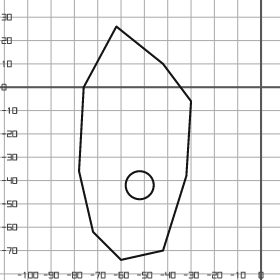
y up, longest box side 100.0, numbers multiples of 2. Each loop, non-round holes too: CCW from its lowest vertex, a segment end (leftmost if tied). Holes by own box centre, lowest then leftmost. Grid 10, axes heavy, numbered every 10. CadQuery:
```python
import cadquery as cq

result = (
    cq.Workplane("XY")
    .moveTo(-60.0, -74.0)
    .lineTo(-42.0, -70.0)
    .lineTo(-32.0, -38.0)
    .lineTo(-30.0, -6.0)
    .lineTo(-42.0, 10.0)
    .lineTo(-62.0, 26.0)
    .lineTo(-76.0, 0.0)
    .lineTo(-78.0, -36.0)
    .lineTo(-72.0, -62.0)
    .close()
    .moveTo(-52.0, -42.0)
    .circle(6.0)
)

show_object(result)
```